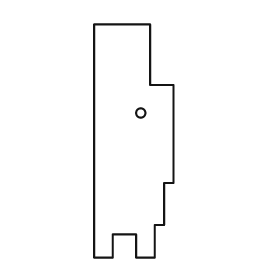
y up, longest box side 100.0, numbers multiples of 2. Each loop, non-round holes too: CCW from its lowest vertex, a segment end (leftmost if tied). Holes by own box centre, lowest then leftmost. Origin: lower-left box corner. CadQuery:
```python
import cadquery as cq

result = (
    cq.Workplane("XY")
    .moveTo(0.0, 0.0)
    .lineTo(8.0, 0.0)
    .lineTo(8.0, 10.0)
    .lineTo(18.0, 10.0)
    .lineTo(18.0, 0.0)
    .lineTo(26.0, 0.0)
    .lineTo(26.0, 14.0)
    .lineTo(30.0, 14.0)
    .lineTo(30.0, 32.0)
    .lineTo(34.0, 32.0)
    .lineTo(34.0, 74.0)
    .lineTo(24.0, 74.0)
    .lineTo(24.0, 100.0)
    .lineTo(0.0, 100.0)
    .close()
    .moveTo(20.0, 62.0)
    .circle(2.0)
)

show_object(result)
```